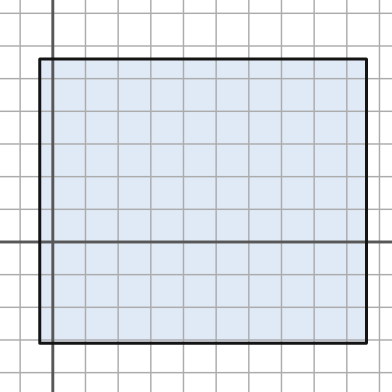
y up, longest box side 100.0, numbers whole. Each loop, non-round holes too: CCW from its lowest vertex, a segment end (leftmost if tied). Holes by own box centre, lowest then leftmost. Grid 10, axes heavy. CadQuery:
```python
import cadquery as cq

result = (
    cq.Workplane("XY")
    .moveTo(-4.0, -31.0)
    .lineTo(96.0, -31.0)
    .lineTo(96.0, 56.0)
    .lineTo(-4.0, 56.0)
    .close()
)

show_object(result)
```